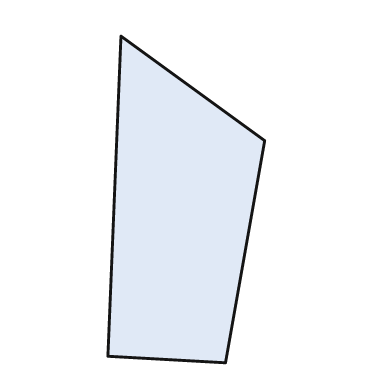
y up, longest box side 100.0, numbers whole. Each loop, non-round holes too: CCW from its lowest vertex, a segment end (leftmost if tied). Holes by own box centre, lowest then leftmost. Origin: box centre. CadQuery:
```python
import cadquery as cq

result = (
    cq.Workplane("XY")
    .moveTo(12.0, -50.0)
    .lineTo(24.0, 18.0)
    .lineTo(-20.0, 50.0)
    .lineTo(-24.0, -48.0)
    .close()
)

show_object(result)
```